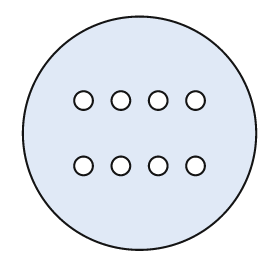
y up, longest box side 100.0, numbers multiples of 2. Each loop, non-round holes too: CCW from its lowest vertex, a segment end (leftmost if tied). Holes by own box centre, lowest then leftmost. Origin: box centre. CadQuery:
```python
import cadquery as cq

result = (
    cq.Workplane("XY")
    .moveTo(0.0, 0.0)
    .circle(50.0)
    .moveTo(-24.0, -14.0)
    .circle(4.0)
    .moveTo(-8.0, -14.0)
    .circle(4.0)
    .moveTo(8.0, -14.0)
    .circle(4.0)
    .moveTo(24.0, -14.0)
    .circle(4.0)
    .moveTo(-24.0, 14.0)
    .circle(4.0)
    .moveTo(-8.0, 14.0)
    .circle(4.0)
    .moveTo(8.0, 14.0)
    .circle(4.0)
    .moveTo(24.0, 14.0)
    .circle(4.0)
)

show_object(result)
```